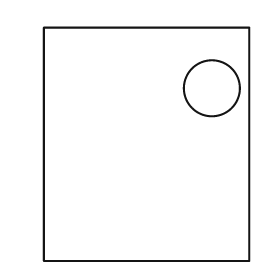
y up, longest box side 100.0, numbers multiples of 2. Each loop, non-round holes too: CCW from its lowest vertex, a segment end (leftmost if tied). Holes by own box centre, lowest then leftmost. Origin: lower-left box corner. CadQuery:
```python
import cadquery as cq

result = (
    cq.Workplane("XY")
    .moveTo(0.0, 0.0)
    .lineTo(88.0, 0.0)
    .lineTo(88.0, 100.0)
    .lineTo(0.0, 100.0)
    .close()
    .moveTo(72.0, 74.0)
    .circle(12.0)
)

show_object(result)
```